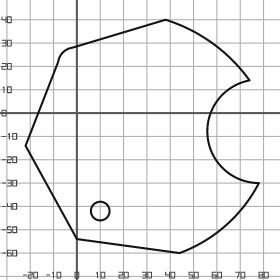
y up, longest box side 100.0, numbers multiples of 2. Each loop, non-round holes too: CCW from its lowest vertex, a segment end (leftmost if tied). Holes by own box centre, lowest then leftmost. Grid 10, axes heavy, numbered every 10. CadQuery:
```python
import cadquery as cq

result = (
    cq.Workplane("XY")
    .moveTo(44.0, -60.0)
    .threePointArc((64.0, -48.0), (78.0, -30.0))
    .threePointArc((56.0, -10.0), (74.0, 14.0))
    .threePointArc((58.0, 30.0), (38.0, 40.0))
    .lineTo(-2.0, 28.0)
    .threePointArc((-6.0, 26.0), (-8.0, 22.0))
    .lineTo(-22.0, -14.0)
    .lineTo(0.0, -54.0)
    .close()
    .moveTo(10.0, -42.0)
    .circle(4.0)
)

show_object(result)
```